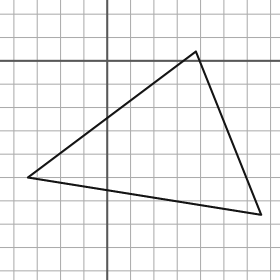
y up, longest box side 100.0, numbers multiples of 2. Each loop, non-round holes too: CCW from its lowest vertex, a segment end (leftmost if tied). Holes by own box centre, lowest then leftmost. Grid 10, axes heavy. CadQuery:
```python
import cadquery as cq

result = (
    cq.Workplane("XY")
    .moveTo(66.0, -66.0)
    .lineTo(38.0, 4.0)
    .lineTo(-34.0, -50.0)
    .close()
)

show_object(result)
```